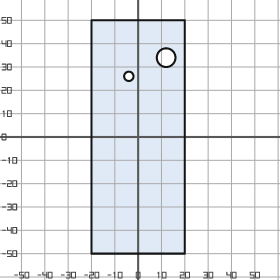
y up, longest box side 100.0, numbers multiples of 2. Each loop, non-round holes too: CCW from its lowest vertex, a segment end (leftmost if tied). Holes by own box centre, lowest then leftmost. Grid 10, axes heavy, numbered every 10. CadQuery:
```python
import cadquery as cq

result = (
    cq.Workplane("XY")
    .moveTo(-20.0, -50.0)
    .lineTo(20.0, -50.0)
    .lineTo(20.0, 50.0)
    .lineTo(-20.0, 50.0)
    .close()
    .moveTo(-4.0, 26.0)
    .circle(2.0)
    .moveTo(12.0, 34.0)
    .circle(4.0)
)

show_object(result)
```